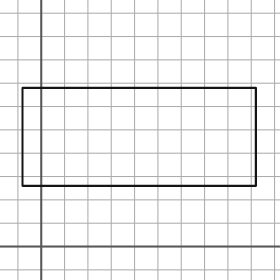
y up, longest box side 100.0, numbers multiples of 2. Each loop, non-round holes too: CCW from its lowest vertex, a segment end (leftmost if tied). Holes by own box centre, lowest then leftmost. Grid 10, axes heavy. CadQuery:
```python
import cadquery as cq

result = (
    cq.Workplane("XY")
    .moveTo(-8.0, 26.0)
    .lineTo(92.0, 26.0)
    .lineTo(92.0, 68.0)
    .lineTo(-8.0, 68.0)
    .close()
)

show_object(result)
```